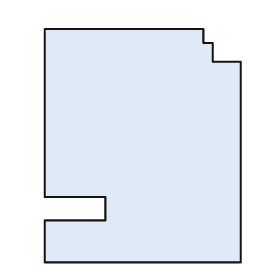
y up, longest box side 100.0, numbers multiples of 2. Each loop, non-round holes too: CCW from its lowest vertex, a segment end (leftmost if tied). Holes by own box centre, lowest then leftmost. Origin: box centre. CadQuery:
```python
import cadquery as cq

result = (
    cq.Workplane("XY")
    .moveTo(-42.0, -50.0)
    .lineTo(42.0, -50.0)
    .lineTo(42.0, 36.0)
    .lineTo(30.0, 36.0)
    .lineTo(30.0, 44.0)
    .lineTo(26.0, 44.0)
    .lineTo(26.0, 50.0)
    .lineTo(-42.0, 50.0)
    .lineTo(-42.0, -22.0)
    .lineTo(-16.0, -22.0)
    .lineTo(-16.0, -32.0)
    .lineTo(-42.0, -32.0)
    .close()
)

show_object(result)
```